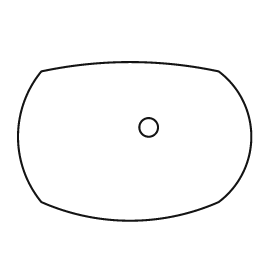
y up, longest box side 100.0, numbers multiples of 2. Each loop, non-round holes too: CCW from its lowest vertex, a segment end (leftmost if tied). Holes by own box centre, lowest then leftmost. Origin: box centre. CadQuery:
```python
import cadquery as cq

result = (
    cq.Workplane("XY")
    .moveTo(-40.0, -26.0)
    .threePointArc((-2.0, -34.0), (36.0, -26.0))
    .threePointArc((50.0, 2.0), (36.0, 30.0))
    .threePointArc((-2.0, 34.0), (-40.0, 30.0))
    .threePointArc((-50.0, 2.0), (-40.0, -26.0))
    .close()
    .moveTo(6.0, 6.0)
    .circle(4.0)
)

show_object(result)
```